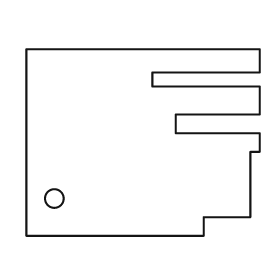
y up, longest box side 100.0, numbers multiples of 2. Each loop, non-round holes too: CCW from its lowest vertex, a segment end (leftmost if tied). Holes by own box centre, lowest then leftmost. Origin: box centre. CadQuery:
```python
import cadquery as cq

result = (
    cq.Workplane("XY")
    .moveTo(-50.0, -40.0)
    .lineTo(26.0, -40.0)
    .lineTo(26.0, -32.0)
    .lineTo(46.0, -32.0)
    .lineTo(46.0, -4.0)
    .lineTo(50.0, -4.0)
    .lineTo(50.0, 4.0)
    .lineTo(14.0, 4.0)
    .lineTo(14.0, 12.0)
    .lineTo(50.0, 12.0)
    .lineTo(50.0, 24.0)
    .lineTo(4.0, 24.0)
    .lineTo(4.0, 30.0)
    .lineTo(50.0, 30.0)
    .lineTo(50.0, 40.0)
    .lineTo(-50.0, 40.0)
    .close()
    .moveTo(-38.0, -24.0)
    .circle(4.0)
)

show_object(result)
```